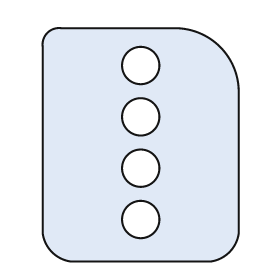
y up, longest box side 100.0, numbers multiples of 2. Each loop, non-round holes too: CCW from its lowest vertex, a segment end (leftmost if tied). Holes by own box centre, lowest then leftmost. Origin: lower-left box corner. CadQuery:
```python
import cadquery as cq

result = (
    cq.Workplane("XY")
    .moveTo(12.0, 0.0)
    .lineTo(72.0, 0.0)
    .threePointArc((80.0, 4.0), (84.0, 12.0))
    .lineTo(84.0, 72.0)
    .threePointArc((76.0, 92.0), (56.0, 100.0))
    .lineTo(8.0, 100.0)
    .threePointArc((2.0, 98.0), (0.0, 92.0))
    .lineTo(0.0, 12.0)
    .threePointArc((4.0, 4.0), (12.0, 0.0))
    .close()
    .moveTo(42.0, 18.0)
    .circle(8.0)
    .moveTo(42.0, 40.0)
    .circle(8.0)
    .moveTo(42.0, 62.0)
    .circle(8.0)
    .moveTo(42.0, 84.0)
    .circle(8.0)
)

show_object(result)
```